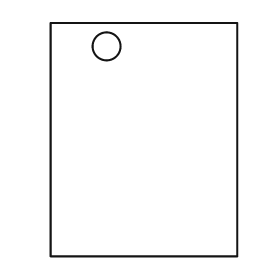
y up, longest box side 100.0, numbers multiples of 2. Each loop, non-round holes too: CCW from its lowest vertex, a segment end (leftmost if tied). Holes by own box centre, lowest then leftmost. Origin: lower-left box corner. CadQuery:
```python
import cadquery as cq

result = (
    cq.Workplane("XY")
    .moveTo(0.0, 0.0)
    .lineTo(80.0, 0.0)
    .lineTo(80.0, 100.0)
    .lineTo(0.0, 100.0)
    .close()
    .moveTo(24.0, 90.0)
    .circle(6.0)
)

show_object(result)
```